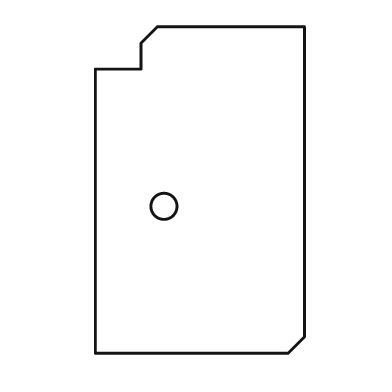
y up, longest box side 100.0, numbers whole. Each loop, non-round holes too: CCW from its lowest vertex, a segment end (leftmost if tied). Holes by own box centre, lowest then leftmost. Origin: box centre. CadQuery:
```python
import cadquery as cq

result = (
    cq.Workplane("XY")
    .moveTo(-32.0, -50.0)
    .lineTo(27.0, -50.0)
    .lineTo(32.0, -45.0)
    .lineTo(32.0, 50.0)
    .lineTo(-13.0, 50.0)
    .lineTo(-18.0, 45.0)
    .lineTo(-18.0, 37.0)
    .lineTo(-32.0, 37.0)
    .close()
    .moveTo(-11.0, -5.0)
    .circle(4.0)
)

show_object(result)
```